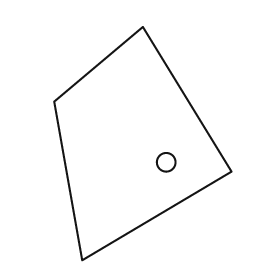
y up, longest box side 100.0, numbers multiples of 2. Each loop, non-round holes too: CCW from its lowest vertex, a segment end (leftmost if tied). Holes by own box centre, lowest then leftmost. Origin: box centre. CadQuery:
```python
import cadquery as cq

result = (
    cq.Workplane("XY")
    .moveTo(-26.0, -50.0)
    .lineTo(38.0, -12.0)
    .lineTo(0.0, 50.0)
    .lineTo(-38.0, 18.0)
    .close()
    .moveTo(10.0, -8.0)
    .circle(4.0)
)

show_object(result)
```